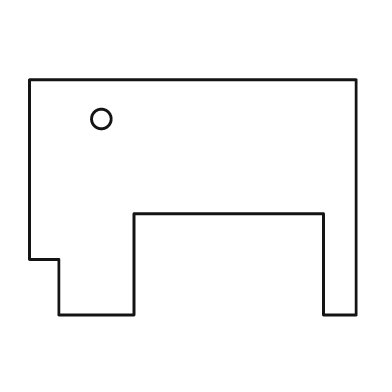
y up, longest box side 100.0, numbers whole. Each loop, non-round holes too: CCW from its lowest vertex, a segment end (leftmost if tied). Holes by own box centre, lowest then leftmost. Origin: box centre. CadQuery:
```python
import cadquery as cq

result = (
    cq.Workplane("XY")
    .moveTo(-41.0, -36.0)
    .lineTo(-18.0, -36.0)
    .lineTo(-18.0, -5.0)
    .lineTo(40.0, -5.0)
    .lineTo(40.0, -36.0)
    .lineTo(50.0, -36.0)
    .lineTo(50.0, 36.0)
    .lineTo(-50.0, 36.0)
    .lineTo(-50.0, -19.0)
    .lineTo(-41.0, -19.0)
    .close()
    .moveTo(-28.0, 24.0)
    .circle(3.0)
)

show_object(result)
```